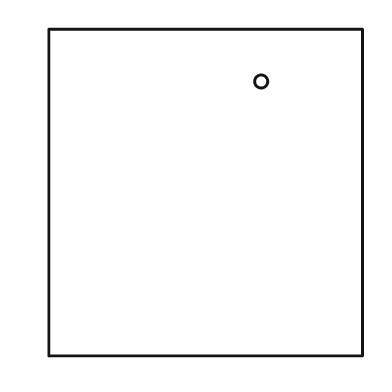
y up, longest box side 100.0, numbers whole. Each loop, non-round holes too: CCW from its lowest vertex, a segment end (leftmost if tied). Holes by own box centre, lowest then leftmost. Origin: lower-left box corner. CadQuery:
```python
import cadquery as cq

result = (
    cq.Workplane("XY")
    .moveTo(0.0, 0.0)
    .lineTo(96.0, 0.0)
    .lineTo(96.0, 100.0)
    .lineTo(0.0, 100.0)
    .close()
    .moveTo(65.0, 84.0)
    .circle(2.0)
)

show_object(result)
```